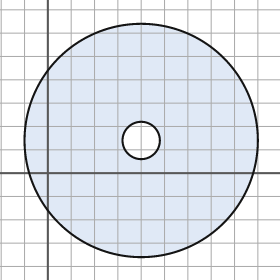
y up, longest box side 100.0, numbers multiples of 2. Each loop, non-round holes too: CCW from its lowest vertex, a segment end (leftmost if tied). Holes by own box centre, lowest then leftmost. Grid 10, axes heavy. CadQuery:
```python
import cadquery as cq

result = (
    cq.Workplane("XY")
    .moveTo(40.0, 14.0)
    .circle(50.0)
    .moveTo(40.0, 14.0)
    .circle(8.0)
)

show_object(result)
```